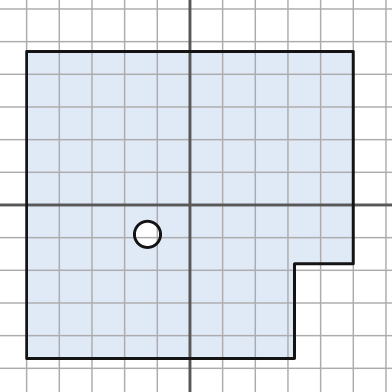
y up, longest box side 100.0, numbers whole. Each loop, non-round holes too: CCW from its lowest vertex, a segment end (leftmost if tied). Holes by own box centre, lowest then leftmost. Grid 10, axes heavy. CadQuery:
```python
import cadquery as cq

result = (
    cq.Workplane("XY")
    .moveTo(-50.0, -47.0)
    .lineTo(32.0, -47.0)
    .lineTo(32.0, -18.0)
    .lineTo(50.0, -18.0)
    .lineTo(50.0, 47.0)
    .lineTo(-50.0, 47.0)
    .close()
    .moveTo(-13.0, -9.0)
    .circle(4.0)
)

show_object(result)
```